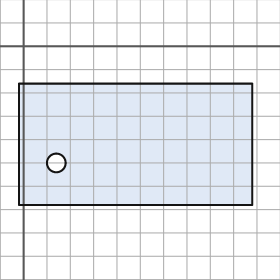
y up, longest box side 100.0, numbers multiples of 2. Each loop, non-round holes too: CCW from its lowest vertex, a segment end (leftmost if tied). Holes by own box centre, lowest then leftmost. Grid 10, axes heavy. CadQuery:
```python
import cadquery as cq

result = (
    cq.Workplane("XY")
    .moveTo(-2.0, -68.0)
    .lineTo(98.0, -68.0)
    .lineTo(98.0, -16.0)
    .lineTo(-2.0, -16.0)
    .close()
    .moveTo(14.0, -50.0)
    .circle(4.0)
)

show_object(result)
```